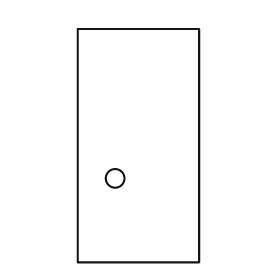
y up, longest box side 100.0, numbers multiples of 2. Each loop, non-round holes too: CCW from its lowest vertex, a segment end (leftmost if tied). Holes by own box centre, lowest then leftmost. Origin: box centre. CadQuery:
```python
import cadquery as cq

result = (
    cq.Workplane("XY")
    .moveTo(-26.0, -50.0)
    .lineTo(26.0, -50.0)
    .lineTo(26.0, 50.0)
    .lineTo(-26.0, 50.0)
    .close()
    .moveTo(-10.0, -14.0)
    .circle(4.0)
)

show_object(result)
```